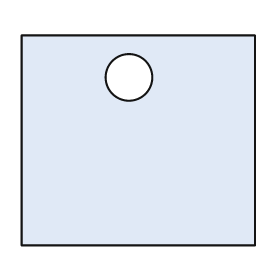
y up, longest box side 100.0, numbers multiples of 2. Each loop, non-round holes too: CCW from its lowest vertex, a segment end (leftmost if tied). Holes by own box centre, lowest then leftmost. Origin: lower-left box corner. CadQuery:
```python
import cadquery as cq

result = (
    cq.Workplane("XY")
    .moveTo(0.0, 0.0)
    .lineTo(100.0, 0.0)
    .lineTo(100.0, 90.0)
    .lineTo(0.0, 90.0)
    .close()
    .moveTo(46.0, 72.0)
    .circle(10.0)
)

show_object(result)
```